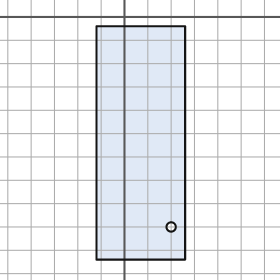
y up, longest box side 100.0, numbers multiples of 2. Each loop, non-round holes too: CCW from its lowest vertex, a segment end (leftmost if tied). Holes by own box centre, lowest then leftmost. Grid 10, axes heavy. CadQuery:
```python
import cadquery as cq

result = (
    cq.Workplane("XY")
    .moveTo(-12.0, -104.0)
    .lineTo(26.0, -104.0)
    .lineTo(26.0, -4.0)
    .lineTo(-12.0, -4.0)
    .close()
    .moveTo(20.0, -90.0)
    .circle(2.0)
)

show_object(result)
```